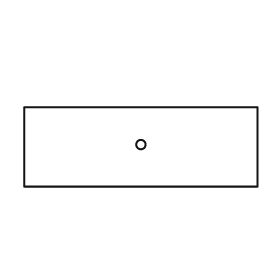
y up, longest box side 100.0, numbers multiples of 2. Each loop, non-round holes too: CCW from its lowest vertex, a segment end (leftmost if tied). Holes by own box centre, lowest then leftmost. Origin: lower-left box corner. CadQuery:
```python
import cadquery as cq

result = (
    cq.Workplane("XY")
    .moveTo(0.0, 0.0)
    .lineTo(100.0, 0.0)
    .lineTo(100.0, 34.0)
    .lineTo(0.0, 34.0)
    .close()
    .moveTo(50.0, 18.0)
    .circle(2.0)
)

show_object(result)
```